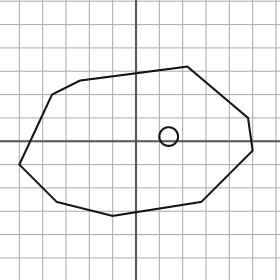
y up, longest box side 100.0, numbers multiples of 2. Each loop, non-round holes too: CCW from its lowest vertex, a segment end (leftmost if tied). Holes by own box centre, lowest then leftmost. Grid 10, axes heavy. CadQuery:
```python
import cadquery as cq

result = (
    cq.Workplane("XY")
    .moveTo(-10.0, -32.0)
    .lineTo(28.0, -26.0)
    .lineTo(50.0, -4.0)
    .lineTo(48.0, 10.0)
    .lineTo(22.0, 32.0)
    .lineTo(-24.0, 26.0)
    .lineTo(-36.0, 20.0)
    .lineTo(-50.0, -10.0)
    .lineTo(-34.0, -26.0)
    .close()
    .moveTo(14.0, 2.0)
    .circle(4.0)
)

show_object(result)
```